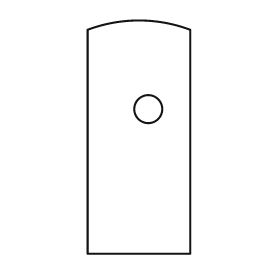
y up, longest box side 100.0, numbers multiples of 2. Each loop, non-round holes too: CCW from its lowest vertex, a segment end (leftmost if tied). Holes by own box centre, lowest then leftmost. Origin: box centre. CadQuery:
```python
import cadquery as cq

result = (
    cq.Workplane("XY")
    .moveTo(-22.0, -50.0)
    .lineTo(22.0, -50.0)
    .lineTo(22.0, 46.0)
    .threePointArc((0.0, 50.0), (-22.0, 46.0))
    .close()
    .moveTo(4.0, 12.0)
    .circle(6.0)
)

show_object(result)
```